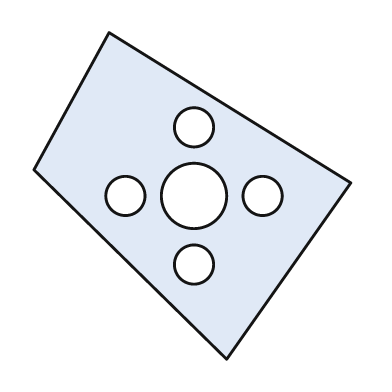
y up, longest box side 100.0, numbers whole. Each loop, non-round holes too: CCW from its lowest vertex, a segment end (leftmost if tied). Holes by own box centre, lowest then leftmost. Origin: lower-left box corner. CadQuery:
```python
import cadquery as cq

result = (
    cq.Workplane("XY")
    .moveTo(59.0, 0.0)
    .lineTo(97.0, 54.0)
    .lineTo(23.0, 100.0)
    .lineTo(0.0, 58.0)
    .close()
    .moveTo(49.0, 29.0)
    .circle(6.0)
    .moveTo(28.0, 50.0)
    .circle(6.0)
    .moveTo(49.0, 50.0)
    .circle(10.0)
    .moveTo(70.0, 50.0)
    .circle(6.0)
    .moveTo(49.0, 71.0)
    .circle(6.0)
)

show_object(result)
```